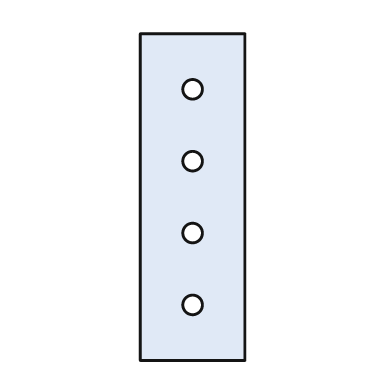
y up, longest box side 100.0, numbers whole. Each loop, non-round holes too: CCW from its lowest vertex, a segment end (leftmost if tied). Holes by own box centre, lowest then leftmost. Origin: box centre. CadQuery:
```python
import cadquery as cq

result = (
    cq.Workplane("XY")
    .moveTo(-16.0, -50.0)
    .lineTo(16.0, -50.0)
    .lineTo(16.0, 50.0)
    .lineTo(-16.0, 50.0)
    .close()
    .moveTo(0.0, -33.0)
    .circle(3.0)
    .moveTo(0.0, -11.0)
    .circle(3.0)
    .moveTo(0.0, 11.0)
    .circle(3.0)
    .moveTo(0.0, 33.0)
    .circle(3.0)
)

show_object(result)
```